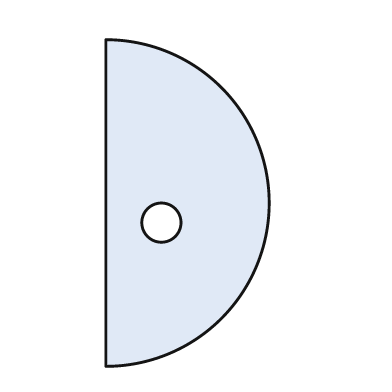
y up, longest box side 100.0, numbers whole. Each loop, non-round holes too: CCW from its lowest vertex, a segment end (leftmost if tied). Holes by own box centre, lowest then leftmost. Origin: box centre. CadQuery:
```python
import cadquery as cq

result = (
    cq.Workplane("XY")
    .moveTo(-25.0, -50.0)
    .threePointArc((25.0, 0.0), (-25.0, 50.0))
    .close()
    .moveTo(-8.0, -6.0)
    .circle(6.0)
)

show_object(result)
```